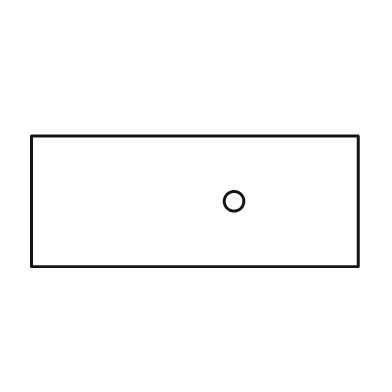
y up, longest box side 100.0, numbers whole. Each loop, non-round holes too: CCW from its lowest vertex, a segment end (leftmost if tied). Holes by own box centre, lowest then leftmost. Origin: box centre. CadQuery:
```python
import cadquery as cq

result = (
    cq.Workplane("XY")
    .moveTo(-50.0, -20.0)
    .lineTo(50.0, -20.0)
    .lineTo(50.0, 20.0)
    .lineTo(-50.0, 20.0)
    .close()
    .moveTo(12.0, 0.0)
    .circle(3.0)
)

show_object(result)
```